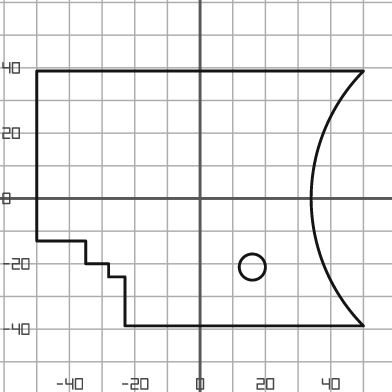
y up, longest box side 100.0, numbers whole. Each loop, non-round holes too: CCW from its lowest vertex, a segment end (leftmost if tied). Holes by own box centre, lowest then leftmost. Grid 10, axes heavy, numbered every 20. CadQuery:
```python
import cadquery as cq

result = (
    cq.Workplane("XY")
    .moveTo(-23.0, -39.0)
    .lineTo(50.0, -39.0)
    .threePointArc((34.0, 0.0), (50.0, 39.0))
    .lineTo(-50.0, 39.0)
    .lineTo(-50.0, -13.0)
    .lineTo(-35.0, -13.0)
    .lineTo(-35.0, -20.0)
    .lineTo(-28.0, -20.0)
    .lineTo(-28.0, -24.0)
    .lineTo(-23.0, -24.0)
    .close()
    .moveTo(16.0, -21.0)
    .circle(4.0)
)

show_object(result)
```